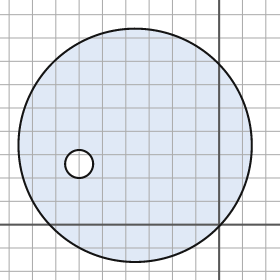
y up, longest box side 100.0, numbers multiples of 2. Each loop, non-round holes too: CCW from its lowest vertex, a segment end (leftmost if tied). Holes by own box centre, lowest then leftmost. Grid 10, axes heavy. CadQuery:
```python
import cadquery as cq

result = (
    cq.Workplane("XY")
    .moveTo(-36.0, 34.0)
    .circle(50.0)
    .moveTo(-60.0, 26.0)
    .circle(6.0)
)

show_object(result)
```